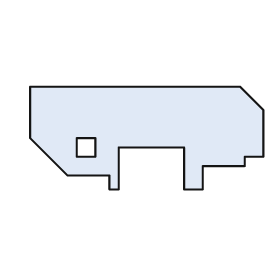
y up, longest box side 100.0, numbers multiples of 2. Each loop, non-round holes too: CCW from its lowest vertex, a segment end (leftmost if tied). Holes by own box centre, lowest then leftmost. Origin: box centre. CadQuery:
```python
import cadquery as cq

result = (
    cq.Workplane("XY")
    .moveTo(-16.0, -22.0)
    .lineTo(-12.0, -22.0)
    .lineTo(-12.0, -4.0)
    .lineTo(16.0, -4.0)
    .lineTo(16.0, -22.0)
    .lineTo(24.0, -22.0)
    .lineTo(24.0, -12.0)
    .lineTo(42.0, -12.0)
    .lineTo(42.0, -8.0)
    .lineTo(50.0, -8.0)
    .lineTo(50.0, 12.0)
    .lineTo(40.0, 22.0)
    .lineTo(-50.0, 22.0)
    .lineTo(-50.0, 0.0)
    .lineTo(-34.0, -16.0)
    .lineTo(-16.0, -16.0)
    .close()
    .moveTo(-30.0, -8.0)
    .lineTo(-22.0, -8.0)
    .lineTo(-22.0, 0.0)
    .lineTo(-30.0, 0.0)
    .close()
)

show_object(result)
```